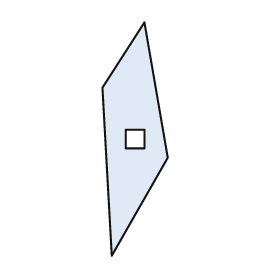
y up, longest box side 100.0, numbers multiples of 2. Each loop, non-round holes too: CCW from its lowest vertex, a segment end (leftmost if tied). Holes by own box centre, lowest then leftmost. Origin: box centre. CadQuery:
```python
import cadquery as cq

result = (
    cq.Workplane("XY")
    .moveTo(-10.0, -50.0)
    .lineTo(14.0, -8.0)
    .lineTo(4.0, 50.0)
    .lineTo(-14.0, 22.0)
    .close()
    .moveTo(-4.0, -4.0)
    .lineTo(4.0, -4.0)
    .lineTo(4.0, 4.0)
    .lineTo(-4.0, 4.0)
    .close()
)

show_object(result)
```